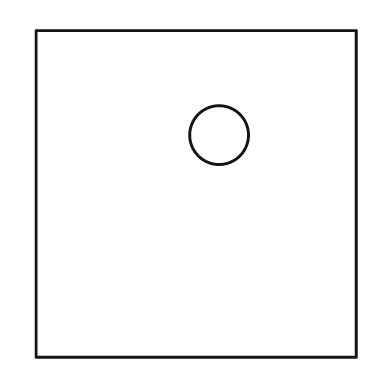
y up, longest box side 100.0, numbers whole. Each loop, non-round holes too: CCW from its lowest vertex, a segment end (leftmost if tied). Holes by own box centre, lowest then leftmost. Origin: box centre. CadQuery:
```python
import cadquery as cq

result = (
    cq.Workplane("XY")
    .moveTo(-49.0, -50.0)
    .lineTo(49.0, -50.0)
    .lineTo(49.0, 50.0)
    .lineTo(-49.0, 50.0)
    .close()
    .moveTo(7.0, 18.0)
    .circle(9.0)
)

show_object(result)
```